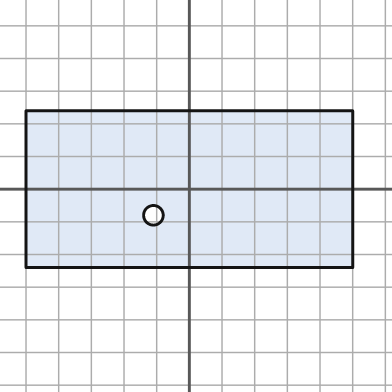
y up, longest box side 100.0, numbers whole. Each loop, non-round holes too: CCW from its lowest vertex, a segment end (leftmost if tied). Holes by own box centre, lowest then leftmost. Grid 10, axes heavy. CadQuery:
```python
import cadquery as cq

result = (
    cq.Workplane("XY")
    .moveTo(-50.0, -24.0)
    .lineTo(50.0, -24.0)
    .lineTo(50.0, 24.0)
    .lineTo(-50.0, 24.0)
    .close()
    .moveTo(-11.0, -8.0)
    .circle(3.0)
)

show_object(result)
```